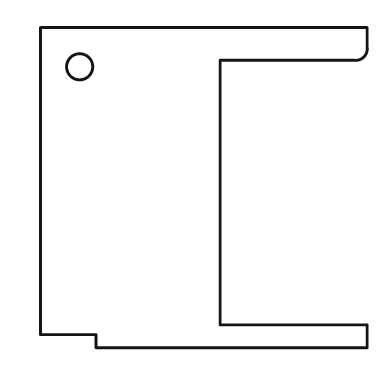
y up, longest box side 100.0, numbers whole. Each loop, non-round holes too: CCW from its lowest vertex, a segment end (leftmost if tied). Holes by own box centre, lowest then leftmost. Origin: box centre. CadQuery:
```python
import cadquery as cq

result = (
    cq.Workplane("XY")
    .moveTo(-33.0, -49.0)
    .lineTo(50.0, -49.0)
    .lineTo(50.0, -42.0)
    .lineTo(5.0, -42.0)
    .lineTo(5.0, 39.0)
    .lineTo(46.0, 39.0)
    .threePointArc((49.0, 40.0), (50.0, 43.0))
    .lineTo(50.0, 49.0)
    .lineTo(-50.0, 49.0)
    .lineTo(-50.0, -45.0)
    .lineTo(-33.0, -45.0)
    .close()
    .moveTo(-38.0, 37.0)
    .circle(4.0)
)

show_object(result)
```